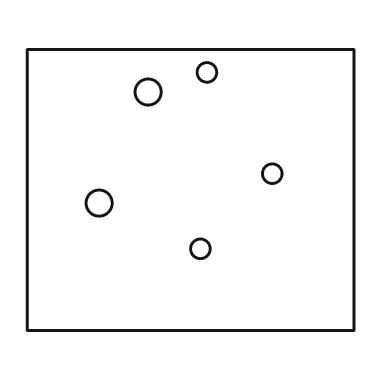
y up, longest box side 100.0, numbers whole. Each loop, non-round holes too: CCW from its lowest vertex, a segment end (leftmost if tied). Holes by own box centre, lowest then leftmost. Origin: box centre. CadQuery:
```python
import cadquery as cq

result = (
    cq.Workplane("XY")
    .moveTo(-50.0, -43.0)
    .lineTo(50.0, -43.0)
    .lineTo(50.0, 43.0)
    .lineTo(-50.0, 43.0)
    .close()
    .moveTo(3.0, -18.0)
    .circle(3.0)
    .moveTo(-28.0, -4.0)
    .circle(4.0)
    .moveTo(25.0, 5.0)
    .circle(3.0)
    .moveTo(-13.0, 30.0)
    .circle(4.0)
    .moveTo(5.0, 36.0)
    .circle(3.0)
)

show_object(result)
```